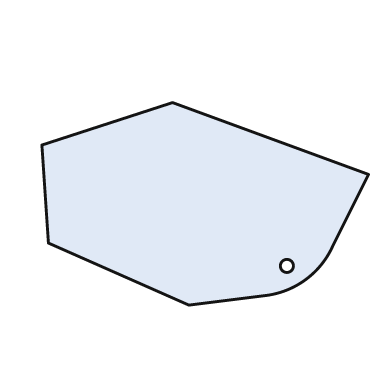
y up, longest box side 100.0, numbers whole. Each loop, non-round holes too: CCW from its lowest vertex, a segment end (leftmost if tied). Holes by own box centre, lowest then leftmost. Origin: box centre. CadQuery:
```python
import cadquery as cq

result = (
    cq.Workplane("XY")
    .moveTo(-5.0, -31.0)
    .lineTo(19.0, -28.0)
    .threePointArc((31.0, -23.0), (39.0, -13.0))
    .lineTo(50.0, 9.0)
    .lineTo(-10.0, 31.0)
    .lineTo(-50.0, 18.0)
    .lineTo(-48.0, -12.0)
    .close()
    .moveTo(25.0, -19.0)
    .circle(2.0)
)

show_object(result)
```